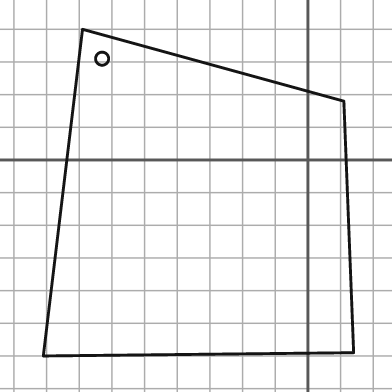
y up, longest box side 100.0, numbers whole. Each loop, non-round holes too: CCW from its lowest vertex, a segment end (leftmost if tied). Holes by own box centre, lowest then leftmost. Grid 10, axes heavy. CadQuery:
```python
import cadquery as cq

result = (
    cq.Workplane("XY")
    .moveTo(-81.0, -60.0)
    .lineTo(14.0, -59.0)
    .lineTo(11.0, 18.0)
    .lineTo(-69.0, 40.0)
    .close()
    .moveTo(-63.0, 31.0)
    .circle(2.0)
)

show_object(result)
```